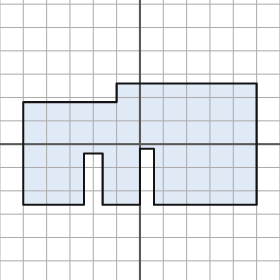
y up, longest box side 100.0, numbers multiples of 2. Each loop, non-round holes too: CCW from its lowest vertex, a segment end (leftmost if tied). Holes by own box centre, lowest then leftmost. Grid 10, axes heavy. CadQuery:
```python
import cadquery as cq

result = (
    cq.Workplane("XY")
    .moveTo(-50.0, -26.0)
    .lineTo(-24.0, -26.0)
    .lineTo(-24.0, -4.0)
    .lineTo(-16.0, -4.0)
    .lineTo(-16.0, -26.0)
    .lineTo(0.0, -26.0)
    .lineTo(0.0, -2.0)
    .lineTo(6.0, -2.0)
    .lineTo(6.0, -26.0)
    .lineTo(50.0, -26.0)
    .lineTo(50.0, 26.0)
    .lineTo(-10.0, 26.0)
    .lineTo(-10.0, 18.0)
    .lineTo(-50.0, 18.0)
    .close()
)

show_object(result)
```